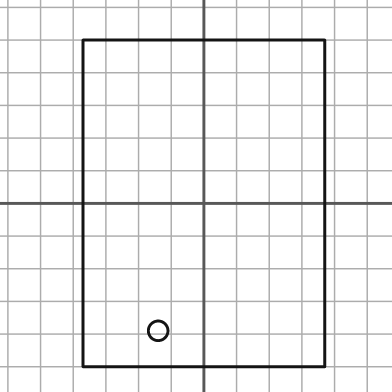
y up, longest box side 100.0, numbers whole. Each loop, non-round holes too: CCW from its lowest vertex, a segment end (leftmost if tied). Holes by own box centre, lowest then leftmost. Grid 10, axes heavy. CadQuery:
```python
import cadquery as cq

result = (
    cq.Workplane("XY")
    .moveTo(-37.0, -50.0)
    .lineTo(37.0, -50.0)
    .lineTo(37.0, 50.0)
    .lineTo(-37.0, 50.0)
    .close()
    .moveTo(-14.0, -39.0)
    .circle(3.0)
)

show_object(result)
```